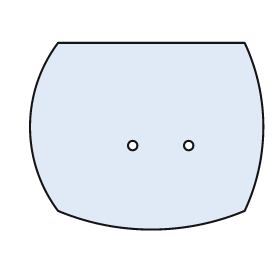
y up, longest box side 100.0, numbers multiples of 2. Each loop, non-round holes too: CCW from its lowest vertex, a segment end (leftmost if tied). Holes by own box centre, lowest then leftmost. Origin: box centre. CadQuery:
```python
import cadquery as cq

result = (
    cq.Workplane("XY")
    .moveTo(-38.0, -32.0)
    .threePointArc((2.0, -40.0), (42.0, -32.0))
    .threePointArc((50.0, 4.0), (42.0, 40.0))
    .lineTo(-38.0, 40.0)
    .threePointArc((-50.0, 4.0), (-38.0, -32.0))
    .close()
    .moveTo(-6.0, -4.0)
    .circle(2.0)
    .moveTo(18.0, -4.0)
    .circle(2.0)
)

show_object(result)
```